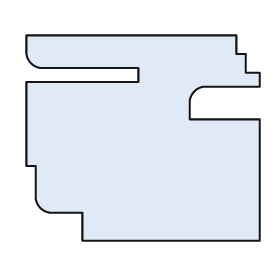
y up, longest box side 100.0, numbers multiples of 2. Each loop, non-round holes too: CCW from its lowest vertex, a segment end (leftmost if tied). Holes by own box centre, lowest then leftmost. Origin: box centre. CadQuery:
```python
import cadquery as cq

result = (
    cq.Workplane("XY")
    .moveTo(-26.0, -44.0)
    .lineTo(50.0, -44.0)
    .lineTo(50.0, 8.0)
    .lineTo(20.0, 8.0)
    .lineTo(20.0, 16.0)
    .threePointArc((22.0, 20.0), (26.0, 22.0))
    .lineTo(50.0, 22.0)
    .lineTo(50.0, 28.0)
    .lineTo(44.0, 28.0)
    .lineTo(44.0, 36.0)
    .lineTo(40.0, 36.0)
    .lineTo(40.0, 44.0)
    .lineTo(-50.0, 44.0)
    .lineTo(-50.0, 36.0)
    .threePointArc((-48.0, 32.0), (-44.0, 30.0))
    .lineTo(-2.0, 30.0)
    .lineTo(-2.0, 24.0)
    .lineTo(-50.0, 24.0)
    .lineTo(-50.0, -12.0)
    .lineTo(-46.0, -12.0)
    .lineTo(-46.0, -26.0)
    .threePointArc((-44.0, -30.0), (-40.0, -32.0))
    .lineTo(-26.0, -32.0)
    .close()
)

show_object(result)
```